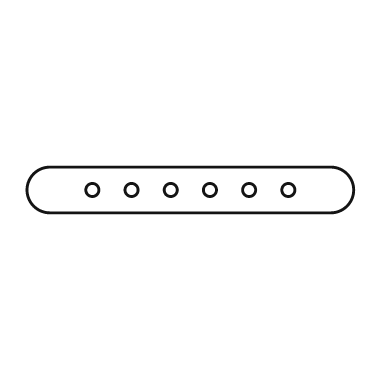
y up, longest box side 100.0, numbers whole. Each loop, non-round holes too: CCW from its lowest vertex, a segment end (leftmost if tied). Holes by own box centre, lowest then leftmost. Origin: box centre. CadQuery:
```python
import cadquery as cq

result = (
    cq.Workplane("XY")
    .moveTo(-43.0, -7.0)
    .lineTo(43.0, -7.0)
    .threePointArc((50.0, 0.0), (43.0, 7.0))
    .lineTo(-43.0, 7.0)
    .threePointArc((-50.0, 0.0), (-43.0, -7.0))
    .close()
    .moveTo(-30.0, 0.0)
    .circle(2.0)
    .moveTo(-18.0, 0.0)
    .circle(2.0)
    .moveTo(-6.0, 0.0)
    .circle(2.0)
    .moveTo(6.0, 0.0)
    .circle(2.0)
    .moveTo(18.0, 0.0)
    .circle(2.0)
    .moveTo(30.0, 0.0)
    .circle(2.0)
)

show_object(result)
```